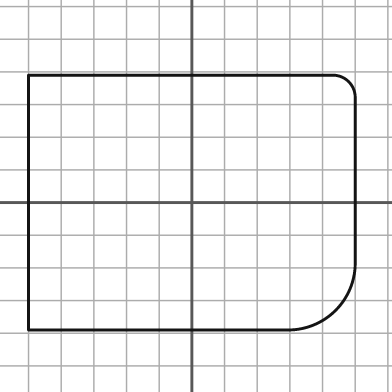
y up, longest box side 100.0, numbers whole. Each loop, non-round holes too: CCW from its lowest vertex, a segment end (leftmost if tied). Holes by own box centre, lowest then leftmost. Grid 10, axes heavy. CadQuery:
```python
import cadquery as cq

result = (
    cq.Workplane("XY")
    .moveTo(-50.0, -39.0)
    .lineTo(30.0, -39.0)
    .threePointArc((44.0, -33.0), (50.0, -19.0))
    .lineTo(50.0, 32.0)
    .threePointArc((48.0, 37.0), (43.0, 39.0))
    .lineTo(-50.0, 39.0)
    .close()
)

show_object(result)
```